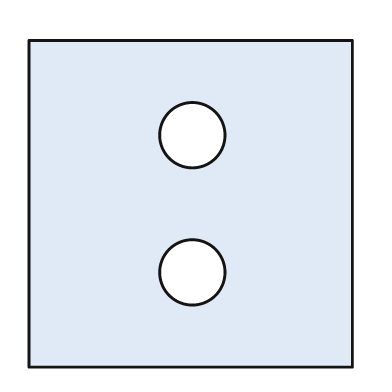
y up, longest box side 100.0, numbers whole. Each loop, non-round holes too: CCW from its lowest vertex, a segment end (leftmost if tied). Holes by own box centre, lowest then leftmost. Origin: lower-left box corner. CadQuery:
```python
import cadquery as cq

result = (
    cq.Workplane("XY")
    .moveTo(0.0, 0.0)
    .lineTo(99.0, 0.0)
    .lineTo(99.0, 100.0)
    .lineTo(0.0, 100.0)
    .close()
    .moveTo(50.0, 29.0)
    .circle(10.0)
    .moveTo(50.0, 71.0)
    .circle(10.0)
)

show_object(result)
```